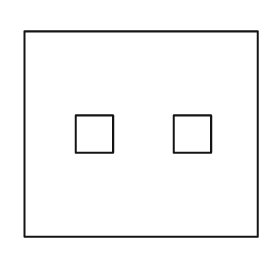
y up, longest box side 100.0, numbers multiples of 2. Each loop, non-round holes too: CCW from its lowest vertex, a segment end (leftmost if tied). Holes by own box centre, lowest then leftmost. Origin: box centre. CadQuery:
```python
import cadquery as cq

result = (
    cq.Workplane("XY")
    .moveTo(-50.0, -44.0)
    .lineTo(50.0, -44.0)
    .lineTo(50.0, 44.0)
    .lineTo(-50.0, 44.0)
    .close()
    .moveTo(-28.0, -8.0)
    .lineTo(-12.0, -8.0)
    .lineTo(-12.0, 8.0)
    .lineTo(-28.0, 8.0)
    .close()
    .moveTo(14.0, -8.0)
    .lineTo(30.0, -8.0)
    .lineTo(30.0, 8.0)
    .lineTo(14.0, 8.0)
    .close()
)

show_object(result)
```